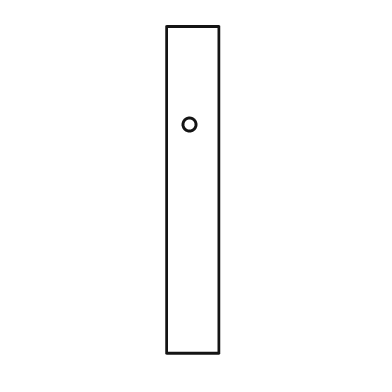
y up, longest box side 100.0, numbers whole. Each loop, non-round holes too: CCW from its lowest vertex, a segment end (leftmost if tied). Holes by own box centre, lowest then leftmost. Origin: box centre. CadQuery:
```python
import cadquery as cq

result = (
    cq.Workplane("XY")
    .moveTo(-8.0, -50.0)
    .lineTo(8.0, -50.0)
    .lineTo(8.0, 50.0)
    .lineTo(-8.0, 50.0)
    .close()
    .moveTo(-1.0, 20.0)
    .circle(2.0)
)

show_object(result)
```